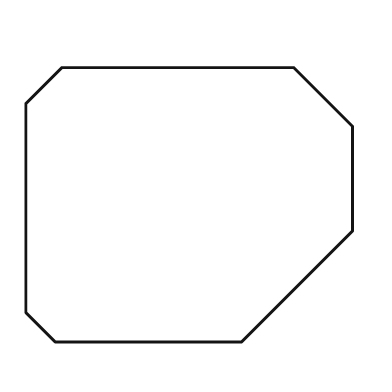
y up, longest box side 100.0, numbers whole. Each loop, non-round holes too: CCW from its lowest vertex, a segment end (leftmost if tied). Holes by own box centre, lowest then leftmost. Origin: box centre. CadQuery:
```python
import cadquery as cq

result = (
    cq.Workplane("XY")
    .moveTo(-41.0, -42.0)
    .lineTo(16.0, -42.0)
    .lineTo(50.0, -8.0)
    .lineTo(50.0, 24.0)
    .lineTo(32.0, 42.0)
    .lineTo(-39.0, 42.0)
    .lineTo(-50.0, 31.0)
    .lineTo(-50.0, -33.0)
    .close()
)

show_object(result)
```